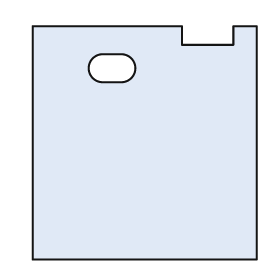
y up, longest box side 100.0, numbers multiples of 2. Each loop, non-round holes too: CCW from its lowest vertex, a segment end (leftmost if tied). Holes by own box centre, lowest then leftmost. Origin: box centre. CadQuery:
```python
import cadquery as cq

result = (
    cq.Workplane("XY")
    .moveTo(-48.0, -50.0)
    .lineTo(48.0, -50.0)
    .lineTo(48.0, 50.0)
    .lineTo(38.0, 50.0)
    .lineTo(38.0, 42.0)
    .lineTo(16.0, 42.0)
    .lineTo(16.0, 50.0)
    .lineTo(-48.0, 50.0)
    .close()
    .moveTo(-18.0, 26.0)
    .lineTo(-10.0, 26.0)
    .threePointArc((-4.0, 32.0), (-10.0, 38.0))
    .lineTo(-18.0, 38.0)
    .threePointArc((-24.0, 32.0), (-18.0, 26.0))
    .close()
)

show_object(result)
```